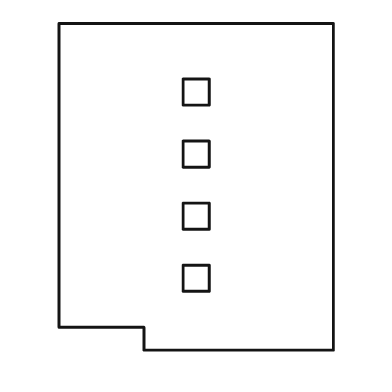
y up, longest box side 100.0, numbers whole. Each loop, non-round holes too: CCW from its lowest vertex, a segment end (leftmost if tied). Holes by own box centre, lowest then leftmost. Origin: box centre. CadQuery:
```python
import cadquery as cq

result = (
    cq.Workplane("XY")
    .moveTo(-16.0, -50.0)
    .lineTo(42.0, -50.0)
    .lineTo(42.0, 50.0)
    .lineTo(-42.0, 50.0)
    .lineTo(-42.0, -43.0)
    .lineTo(-16.0, -43.0)
    .close()
    .moveTo(-4.0, -32.0)
    .lineTo(4.0, -32.0)
    .lineTo(4.0, -24.0)
    .lineTo(-4.0, -24.0)
    .close()
    .moveTo(-4.0, -13.0)
    .lineTo(4.0, -13.0)
    .lineTo(4.0, -5.0)
    .lineTo(-4.0, -5.0)
    .close()
    .moveTo(-4.0, 6.0)
    .lineTo(4.0, 6.0)
    .lineTo(4.0, 14.0)
    .lineTo(-4.0, 14.0)
    .close()
    .moveTo(-4.0, 25.0)
    .lineTo(4.0, 25.0)
    .lineTo(4.0, 33.0)
    .lineTo(-4.0, 33.0)
    .close()
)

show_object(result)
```